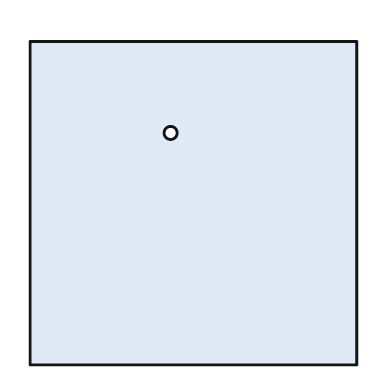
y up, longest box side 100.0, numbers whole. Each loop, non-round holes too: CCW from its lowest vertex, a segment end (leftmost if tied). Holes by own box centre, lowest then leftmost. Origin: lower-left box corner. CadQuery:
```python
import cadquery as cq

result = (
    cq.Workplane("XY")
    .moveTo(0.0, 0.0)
    .lineTo(100.0, 0.0)
    .lineTo(100.0, 99.0)
    .lineTo(0.0, 99.0)
    .close()
    .moveTo(43.0, 71.0)
    .circle(2.0)
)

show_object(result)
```